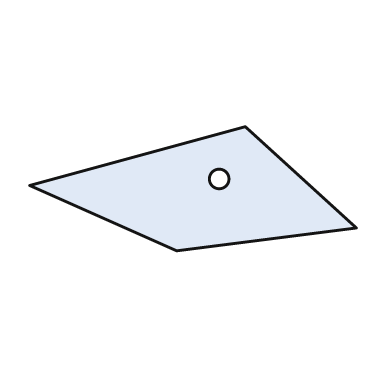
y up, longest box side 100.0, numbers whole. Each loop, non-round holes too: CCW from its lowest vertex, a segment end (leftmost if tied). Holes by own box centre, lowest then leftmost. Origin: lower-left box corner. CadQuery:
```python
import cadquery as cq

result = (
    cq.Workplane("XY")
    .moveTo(45.0, 0.0)
    .lineTo(100.0, 7.0)
    .lineTo(66.0, 38.0)
    .lineTo(0.0, 20.0)
    .close()
    .moveTo(58.0, 22.0)
    .circle(3.0)
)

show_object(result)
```